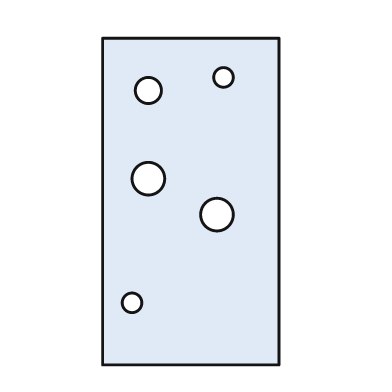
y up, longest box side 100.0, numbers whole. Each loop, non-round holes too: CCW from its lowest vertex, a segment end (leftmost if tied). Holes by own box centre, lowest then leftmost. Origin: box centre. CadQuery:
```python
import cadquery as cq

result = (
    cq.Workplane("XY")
    .moveTo(-27.0, -50.0)
    .lineTo(27.0, -50.0)
    .lineTo(27.0, 50.0)
    .lineTo(-27.0, 50.0)
    .close()
    .moveTo(-18.0, -31.0)
    .circle(3.0)
    .moveTo(8.0, -4.0)
    .circle(5.0)
    .moveTo(-13.0, 7.0)
    .circle(5.0)
    .moveTo(-13.0, 34.0)
    .circle(4.0)
    .moveTo(10.0, 38.0)
    .circle(3.0)
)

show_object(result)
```